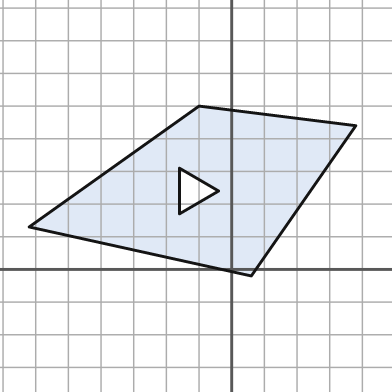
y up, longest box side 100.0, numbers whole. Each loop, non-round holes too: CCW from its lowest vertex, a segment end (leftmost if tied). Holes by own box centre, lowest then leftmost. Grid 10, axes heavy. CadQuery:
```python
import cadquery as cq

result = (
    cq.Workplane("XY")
    .moveTo(6.0, -2.0)
    .lineTo(38.0, 44.0)
    .lineTo(-10.0, 50.0)
    .lineTo(-62.0, 13.0)
    .close()
    .moveTo(-16.0, 17.0)
    .lineTo(-4.0, 24.0)
    .lineTo(-16.0, 31.0)
    .close()
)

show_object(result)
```